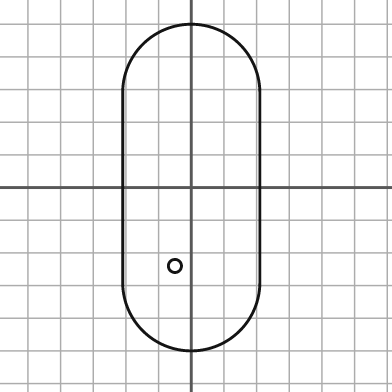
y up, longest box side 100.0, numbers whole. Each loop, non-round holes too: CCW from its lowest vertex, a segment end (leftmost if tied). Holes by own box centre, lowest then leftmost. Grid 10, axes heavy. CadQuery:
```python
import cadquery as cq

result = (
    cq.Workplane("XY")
    .moveTo(-21.0, -29.0)
    .threePointArc((0.0, -50.0), (21.0, -29.0))
    .lineTo(21.0, 29.0)
    .threePointArc((0.0, 50.0), (-21.0, 29.0))
    .close()
    .moveTo(-5.0, -24.0)
    .circle(2.0)
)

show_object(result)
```